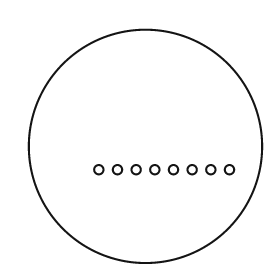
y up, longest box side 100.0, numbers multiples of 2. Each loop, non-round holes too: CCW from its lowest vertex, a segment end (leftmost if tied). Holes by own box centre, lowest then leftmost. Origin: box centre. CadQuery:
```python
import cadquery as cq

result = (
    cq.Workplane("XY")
    .moveTo(0.0, 0.0)
    .circle(50.0)
    .moveTo(-20.0, -10.0)
    .circle(2.0)
    .moveTo(-12.0, -10.0)
    .circle(2.0)
    .moveTo(-4.0, -10.0)
    .circle(2.0)
    .moveTo(4.0, -10.0)
    .circle(2.0)
    .moveTo(12.0, -10.0)
    .circle(2.0)
    .moveTo(20.0, -10.0)
    .circle(2.0)
    .moveTo(28.0, -10.0)
    .circle(2.0)
    .moveTo(36.0, -10.0)
    .circle(2.0)
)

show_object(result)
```